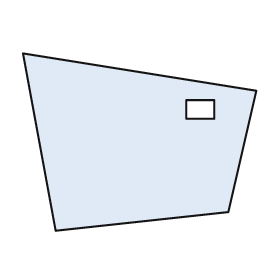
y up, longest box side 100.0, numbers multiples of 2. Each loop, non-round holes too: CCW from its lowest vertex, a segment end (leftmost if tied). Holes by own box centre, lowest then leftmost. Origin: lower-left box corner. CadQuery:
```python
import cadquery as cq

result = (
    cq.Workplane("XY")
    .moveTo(14.0, 0.0)
    .lineTo(88.0, 8.0)
    .lineTo(100.0, 60.0)
    .lineTo(0.0, 76.0)
    .close()
    .moveTo(70.0, 48.0)
    .lineTo(82.0, 48.0)
    .lineTo(82.0, 56.0)
    .lineTo(70.0, 56.0)
    .close()
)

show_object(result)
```